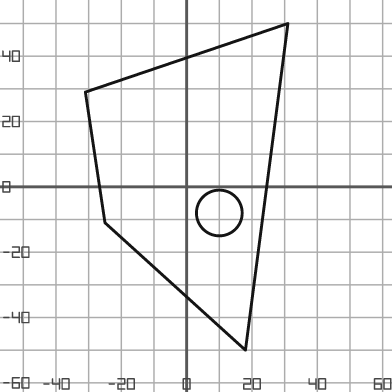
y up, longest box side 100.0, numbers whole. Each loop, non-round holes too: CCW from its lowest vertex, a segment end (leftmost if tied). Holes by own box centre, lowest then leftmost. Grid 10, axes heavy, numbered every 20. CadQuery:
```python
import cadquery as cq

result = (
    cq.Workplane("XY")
    .moveTo(18.0, -50.0)
    .lineTo(31.0, 50.0)
    .lineTo(-31.0, 29.0)
    .lineTo(-25.0, -11.0)
    .close()
    .moveTo(10.0, -8.0)
    .circle(7.0)
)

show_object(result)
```